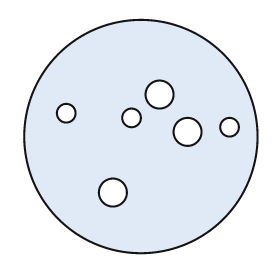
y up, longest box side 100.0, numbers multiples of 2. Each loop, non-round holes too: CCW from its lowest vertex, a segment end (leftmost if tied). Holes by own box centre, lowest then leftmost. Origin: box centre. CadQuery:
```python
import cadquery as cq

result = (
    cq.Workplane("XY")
    .moveTo(0.0, 0.0)
    .circle(50.0)
    .moveTo(-12.0, -24.0)
    .circle(6.0)
    .moveTo(20.0, 2.0)
    .circle(6.0)
    .moveTo(38.0, 4.0)
    .circle(4.0)
    .moveTo(-4.0, 8.0)
    .circle(4.0)
    .moveTo(-32.0, 10.0)
    .circle(4.0)
    .moveTo(8.0, 18.0)
    .circle(6.0)
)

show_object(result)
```